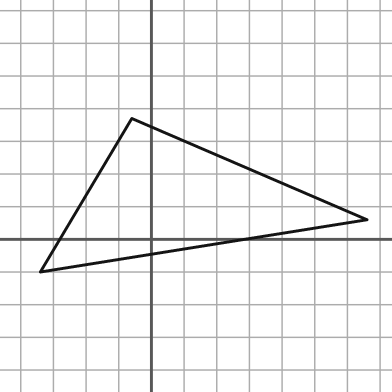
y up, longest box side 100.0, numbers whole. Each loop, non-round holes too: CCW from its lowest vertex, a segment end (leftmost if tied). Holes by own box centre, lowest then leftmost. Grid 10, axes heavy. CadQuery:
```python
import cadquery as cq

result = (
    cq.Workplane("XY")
    .moveTo(-34.0, -10.0)
    .lineTo(66.0, 6.0)
    .lineTo(-6.0, 37.0)
    .close()
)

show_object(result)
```